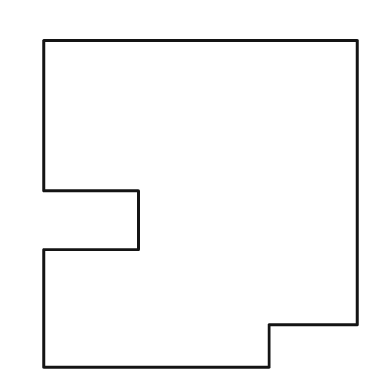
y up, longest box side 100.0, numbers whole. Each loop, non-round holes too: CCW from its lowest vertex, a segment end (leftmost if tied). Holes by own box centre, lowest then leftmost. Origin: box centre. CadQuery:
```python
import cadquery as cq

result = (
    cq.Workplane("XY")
    .moveTo(-48.0, -50.0)
    .lineTo(21.0, -50.0)
    .lineTo(21.0, -37.0)
    .lineTo(48.0, -37.0)
    .lineTo(48.0, 50.0)
    .lineTo(-48.0, 50.0)
    .lineTo(-48.0, 4.0)
    .lineTo(-19.0, 4.0)
    .lineTo(-19.0, -14.0)
    .lineTo(-48.0, -14.0)
    .close()
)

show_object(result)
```